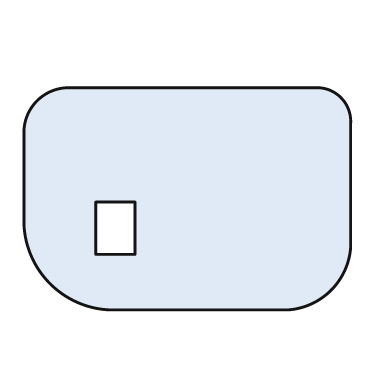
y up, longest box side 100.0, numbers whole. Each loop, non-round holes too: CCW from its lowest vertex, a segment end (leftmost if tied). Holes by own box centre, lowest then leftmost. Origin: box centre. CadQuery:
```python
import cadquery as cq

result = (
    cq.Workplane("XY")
    .moveTo(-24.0, -34.0)
    .lineTo(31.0, -34.0)
    .threePointArc((44.0, -28.0), (50.0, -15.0))
    .lineTo(50.0, 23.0)
    .threePointArc((47.0, 31.0), (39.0, 34.0))
    .lineTo(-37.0, 34.0)
    .threePointArc((-46.0, 30.0), (-50.0, 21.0))
    .lineTo(-50.0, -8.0)
    .threePointArc((-42.0, -26.0), (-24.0, -34.0))
    .close()
    .moveTo(-28.0, -17.0)
    .lineTo(-16.0, -17.0)
    .lineTo(-16.0, -1.0)
    .lineTo(-28.0, -1.0)
    .close()
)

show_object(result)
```